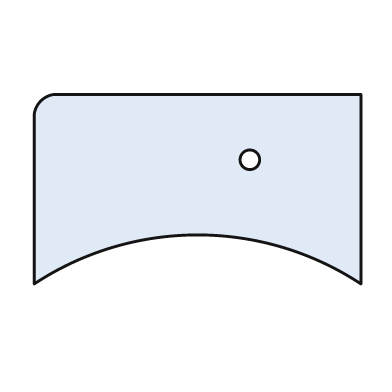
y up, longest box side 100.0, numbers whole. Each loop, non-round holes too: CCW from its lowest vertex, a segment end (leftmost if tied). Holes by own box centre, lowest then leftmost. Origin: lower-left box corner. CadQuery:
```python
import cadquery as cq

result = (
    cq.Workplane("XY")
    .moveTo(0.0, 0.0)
    .threePointArc((50.0, 15.0), (100.0, 0.0))
    .lineTo(100.0, 58.0)
    .lineTo(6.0, 58.0)
    .threePointArc((2.0, 56.0), (0.0, 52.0))
    .close()
    .moveTo(66.0, 38.0)
    .circle(3.0)
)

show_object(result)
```